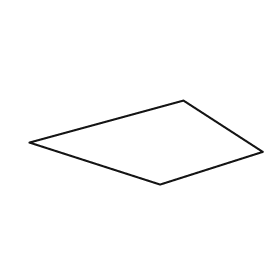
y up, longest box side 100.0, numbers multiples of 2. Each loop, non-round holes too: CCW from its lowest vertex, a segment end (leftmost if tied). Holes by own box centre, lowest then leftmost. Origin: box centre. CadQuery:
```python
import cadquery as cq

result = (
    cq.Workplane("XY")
    .moveTo(6.0, -18.0)
    .lineTo(50.0, -4.0)
    .lineTo(16.0, 18.0)
    .lineTo(-50.0, 0.0)
    .close()
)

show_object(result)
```